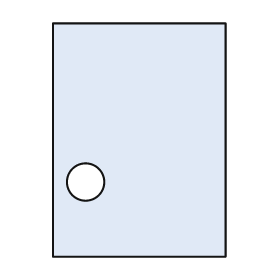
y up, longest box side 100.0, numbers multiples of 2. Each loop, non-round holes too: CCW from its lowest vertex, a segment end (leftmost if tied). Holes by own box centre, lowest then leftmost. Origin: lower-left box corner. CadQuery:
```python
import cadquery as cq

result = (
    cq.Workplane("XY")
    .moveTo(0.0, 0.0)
    .lineTo(74.0, 0.0)
    .lineTo(74.0, 100.0)
    .lineTo(0.0, 100.0)
    .close()
    .moveTo(14.0, 32.0)
    .circle(8.0)
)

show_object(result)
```